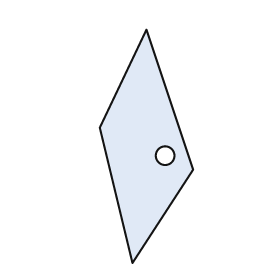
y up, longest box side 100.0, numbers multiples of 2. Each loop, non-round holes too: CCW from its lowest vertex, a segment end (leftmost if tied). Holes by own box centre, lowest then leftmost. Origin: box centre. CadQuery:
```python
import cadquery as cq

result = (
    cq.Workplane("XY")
    .moveTo(-6.0, -50.0)
    .lineTo(20.0, -10.0)
    .lineTo(0.0, 50.0)
    .lineTo(-20.0, 8.0)
    .close()
    .moveTo(8.0, -4.0)
    .circle(4.0)
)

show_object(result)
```